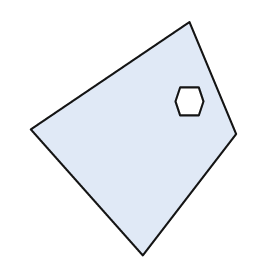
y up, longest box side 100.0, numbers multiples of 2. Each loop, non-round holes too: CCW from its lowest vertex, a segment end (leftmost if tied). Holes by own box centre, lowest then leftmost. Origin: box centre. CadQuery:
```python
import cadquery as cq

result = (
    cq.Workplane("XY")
    .moveTo(4.0, -50.0)
    .lineTo(44.0, 2.0)
    .lineTo(24.0, 50.0)
    .lineTo(-44.0, 4.0)
    .close()
    .moveTo(20.0, 10.0)
    .lineTo(28.0, 10.0)
    .lineTo(30.0, 16.0)
    .lineTo(28.0, 22.0)
    .lineTo(20.0, 22.0)
    .lineTo(18.0, 16.0)
    .close()
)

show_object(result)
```